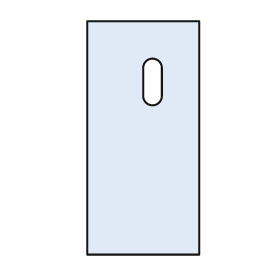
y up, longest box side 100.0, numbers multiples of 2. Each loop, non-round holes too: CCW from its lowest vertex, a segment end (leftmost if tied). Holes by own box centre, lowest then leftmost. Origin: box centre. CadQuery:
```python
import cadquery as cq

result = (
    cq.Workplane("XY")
    .moveTo(-24.0, -50.0)
    .lineTo(24.0, -50.0)
    .lineTo(24.0, 50.0)
    .lineTo(-24.0, 50.0)
    .close()
    .moveTo(0.0, 18.0)
    .threePointArc((4.0, 14.0), (8.0, 18.0))
    .lineTo(8.0, 30.0)
    .threePointArc((4.0, 34.0), (0.0, 30.0))
    .close()
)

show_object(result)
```